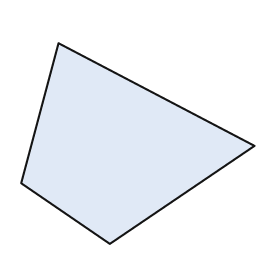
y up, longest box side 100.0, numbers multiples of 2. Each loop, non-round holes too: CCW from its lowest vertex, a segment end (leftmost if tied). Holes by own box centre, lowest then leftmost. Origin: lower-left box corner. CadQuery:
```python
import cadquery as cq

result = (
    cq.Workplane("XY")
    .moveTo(38.0, 0.0)
    .lineTo(100.0, 42.0)
    .lineTo(16.0, 86.0)
    .lineTo(0.0, 26.0)
    .close()
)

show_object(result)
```